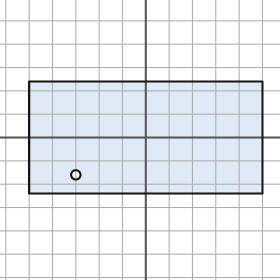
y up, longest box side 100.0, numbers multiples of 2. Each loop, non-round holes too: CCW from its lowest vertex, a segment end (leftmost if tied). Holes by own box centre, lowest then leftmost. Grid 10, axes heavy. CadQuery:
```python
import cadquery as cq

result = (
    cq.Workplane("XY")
    .moveTo(-50.0, -24.0)
    .lineTo(50.0, -24.0)
    .lineTo(50.0, 24.0)
    .lineTo(-50.0, 24.0)
    .close()
    .moveTo(-30.0, -16.0)
    .circle(2.0)
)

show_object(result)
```